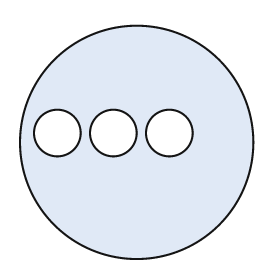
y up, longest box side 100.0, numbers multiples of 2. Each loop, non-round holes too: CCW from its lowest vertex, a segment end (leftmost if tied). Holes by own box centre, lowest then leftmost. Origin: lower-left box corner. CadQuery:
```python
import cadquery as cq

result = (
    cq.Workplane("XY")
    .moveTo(50.0, 50.0)
    .circle(50.0)
    .moveTo(16.0, 54.0)
    .circle(10.0)
    .moveTo(40.0, 54.0)
    .circle(10.0)
    .moveTo(64.0, 54.0)
    .circle(10.0)
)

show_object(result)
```